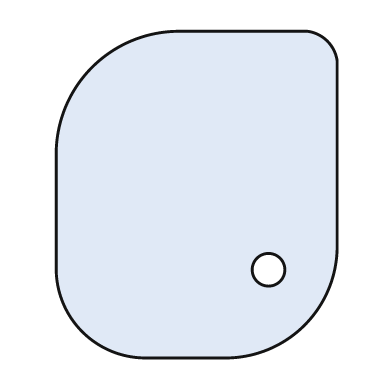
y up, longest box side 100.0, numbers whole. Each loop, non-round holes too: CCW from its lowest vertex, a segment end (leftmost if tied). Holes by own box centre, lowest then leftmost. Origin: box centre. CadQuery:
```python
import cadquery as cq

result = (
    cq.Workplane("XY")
    .moveTo(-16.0, -50.0)
    .lineTo(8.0, -50.0)
    .threePointArc((33.0, -40.0), (43.0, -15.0))
    .lineTo(43.0, 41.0)
    .threePointArc((40.0, 47.0), (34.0, 50.0))
    .lineTo(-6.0, 50.0)
    .threePointArc((-32.0, 39.0), (-43.0, 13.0))
    .lineTo(-43.0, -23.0)
    .threePointArc((-35.0, -42.0), (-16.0, -50.0))
    .close()
    .moveTo(22.0, -23.0)
    .circle(5.0)
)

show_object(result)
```